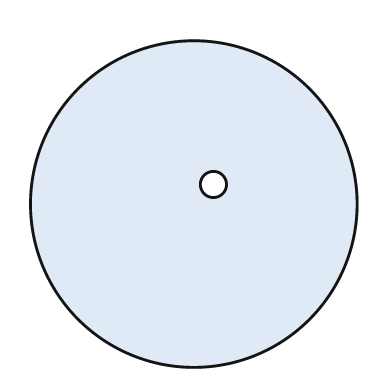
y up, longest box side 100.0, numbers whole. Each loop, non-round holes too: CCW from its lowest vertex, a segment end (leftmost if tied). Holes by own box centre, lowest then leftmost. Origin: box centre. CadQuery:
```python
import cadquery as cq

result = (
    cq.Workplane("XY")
    .moveTo(0.0, 0.0)
    .circle(50.0)
    .moveTo(6.0, 6.0)
    .circle(4.0)
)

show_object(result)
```